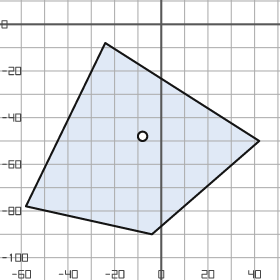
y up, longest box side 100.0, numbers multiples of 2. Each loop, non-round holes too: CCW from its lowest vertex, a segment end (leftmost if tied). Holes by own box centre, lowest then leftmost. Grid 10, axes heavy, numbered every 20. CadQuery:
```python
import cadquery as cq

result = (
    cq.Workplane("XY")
    .moveTo(-4.0, -90.0)
    .lineTo(42.0, -50.0)
    .lineTo(-24.0, -8.0)
    .lineTo(-58.0, -78.0)
    .close()
    .moveTo(-8.0, -48.0)
    .circle(2.0)
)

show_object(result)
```